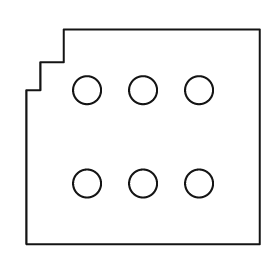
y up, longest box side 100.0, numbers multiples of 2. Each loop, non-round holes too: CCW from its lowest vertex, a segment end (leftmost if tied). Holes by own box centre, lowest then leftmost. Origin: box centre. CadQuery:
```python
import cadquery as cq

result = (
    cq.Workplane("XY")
    .moveTo(-50.0, -46.0)
    .lineTo(50.0, -46.0)
    .lineTo(50.0, 46.0)
    .lineTo(-34.0, 46.0)
    .lineTo(-34.0, 32.0)
    .lineTo(-44.0, 32.0)
    .lineTo(-44.0, 20.0)
    .lineTo(-50.0, 20.0)
    .close()
    .moveTo(-24.0, -20.0)
    .circle(6.0)
    .moveTo(0.0, -20.0)
    .circle(6.0)
    .moveTo(24.0, -20.0)
    .circle(6.0)
    .moveTo(-24.0, 20.0)
    .circle(6.0)
    .moveTo(0.0, 20.0)
    .circle(6.0)
    .moveTo(24.0, 20.0)
    .circle(6.0)
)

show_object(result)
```